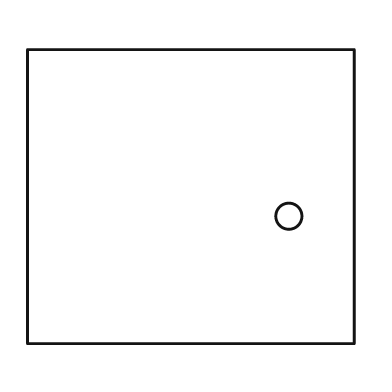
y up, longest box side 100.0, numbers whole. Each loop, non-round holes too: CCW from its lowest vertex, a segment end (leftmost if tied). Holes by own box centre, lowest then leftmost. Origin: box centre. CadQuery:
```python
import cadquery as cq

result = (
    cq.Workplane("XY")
    .moveTo(-50.0, -45.0)
    .lineTo(50.0, -45.0)
    .lineTo(50.0, 45.0)
    .lineTo(-50.0, 45.0)
    .close()
    .moveTo(30.0, -6.0)
    .circle(4.0)
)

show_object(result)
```